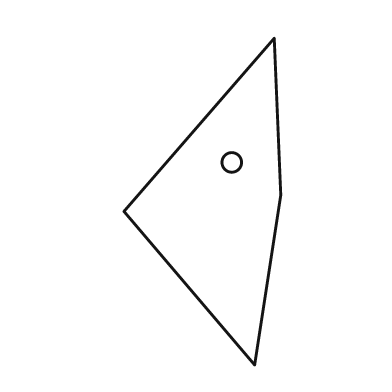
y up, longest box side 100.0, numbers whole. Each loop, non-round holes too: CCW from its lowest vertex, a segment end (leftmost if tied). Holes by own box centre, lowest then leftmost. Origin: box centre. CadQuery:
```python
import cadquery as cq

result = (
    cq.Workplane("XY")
    .moveTo(16.0, -50.0)
    .lineTo(24.0, 2.0)
    .lineTo(22.0, 50.0)
    .lineTo(-24.0, -3.0)
    .close()
    .moveTo(9.0, 12.0)
    .circle(3.0)
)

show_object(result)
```